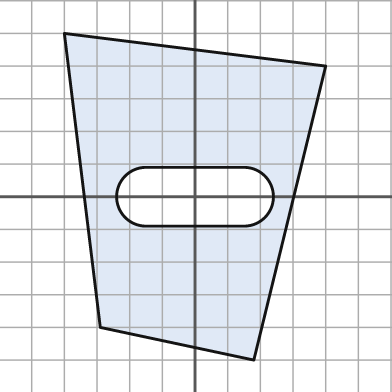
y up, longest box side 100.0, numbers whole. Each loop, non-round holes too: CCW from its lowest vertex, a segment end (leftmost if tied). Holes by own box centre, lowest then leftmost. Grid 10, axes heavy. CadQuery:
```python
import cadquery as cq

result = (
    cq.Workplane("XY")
    .moveTo(18.0, -50.0)
    .lineTo(40.0, 40.0)
    .lineTo(-40.0, 50.0)
    .lineTo(-29.0, -40.0)
    .close()
    .moveTo(-15.0, -9.0)
    .lineTo(15.0, -9.0)
    .threePointArc((24.0, 0.0), (15.0, 9.0))
    .lineTo(-15.0, 9.0)
    .threePointArc((-24.0, 0.0), (-15.0, -9.0))
    .close()
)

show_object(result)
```